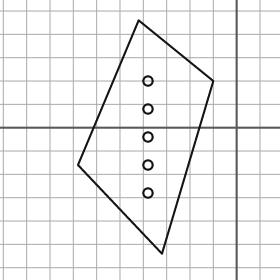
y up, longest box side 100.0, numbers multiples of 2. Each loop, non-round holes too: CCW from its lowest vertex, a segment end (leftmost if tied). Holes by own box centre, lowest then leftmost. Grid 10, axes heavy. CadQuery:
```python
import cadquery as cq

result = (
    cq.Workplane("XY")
    .moveTo(-32.0, -54.0)
    .lineTo(-10.0, 20.0)
    .lineTo(-42.0, 46.0)
    .lineTo(-68.0, -16.0)
    .close()
    .moveTo(-38.0, -28.0)
    .circle(2.0)
    .moveTo(-38.0, -16.0)
    .circle(2.0)
    .moveTo(-38.0, -4.0)
    .circle(2.0)
    .moveTo(-38.0, 8.0)
    .circle(2.0)
    .moveTo(-38.0, 20.0)
    .circle(2.0)
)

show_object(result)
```